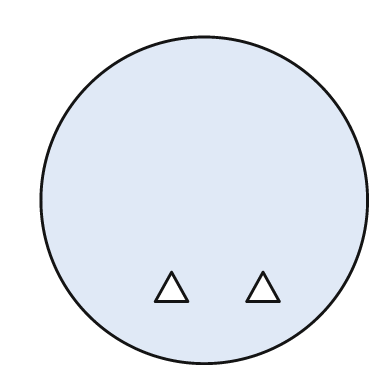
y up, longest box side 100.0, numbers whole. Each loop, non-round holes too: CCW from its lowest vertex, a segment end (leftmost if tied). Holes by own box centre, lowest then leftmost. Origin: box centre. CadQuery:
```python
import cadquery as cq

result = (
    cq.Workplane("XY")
    .moveTo(0.0, 0.0)
    .circle(50.0)
    .moveTo(-15.0, -31.0)
    .lineTo(-5.0, -31.0)
    .lineTo(-10.0, -22.0)
    .close()
    .moveTo(13.0, -31.0)
    .lineTo(23.0, -31.0)
    .lineTo(18.0, -22.0)
    .close()
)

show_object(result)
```